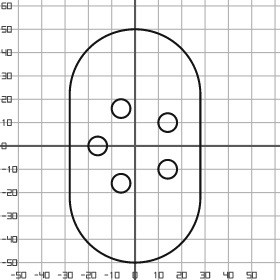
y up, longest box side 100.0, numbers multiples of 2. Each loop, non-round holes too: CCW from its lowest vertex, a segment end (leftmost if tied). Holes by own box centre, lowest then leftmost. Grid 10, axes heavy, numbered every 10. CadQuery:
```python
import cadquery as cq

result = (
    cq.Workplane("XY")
    .moveTo(-28.0, -22.0)
    .threePointArc((0.0, -50.0), (28.0, -22.0))
    .lineTo(28.0, 22.0)
    .threePointArc((0.0, 50.0), (-28.0, 22.0))
    .close()
    .moveTo(-6.0, -16.0)
    .circle(4.0)
    .moveTo(14.0, -10.0)
    .circle(4.0)
    .moveTo(-16.0, 0.0)
    .circle(4.0)
    .moveTo(14.0, 10.0)
    .circle(4.0)
    .moveTo(-6.0, 16.0)
    .circle(4.0)
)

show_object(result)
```